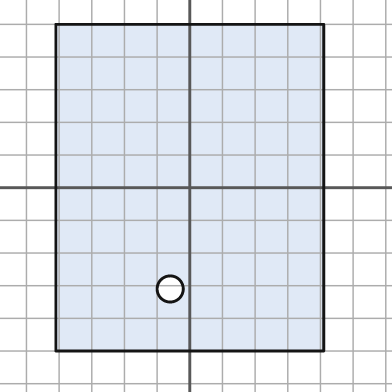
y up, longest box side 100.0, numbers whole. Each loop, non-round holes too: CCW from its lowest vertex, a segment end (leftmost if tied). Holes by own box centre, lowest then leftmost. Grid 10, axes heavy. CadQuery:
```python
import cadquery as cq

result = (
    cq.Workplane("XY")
    .moveTo(-41.0, -50.0)
    .lineTo(41.0, -50.0)
    .lineTo(41.0, 50.0)
    .lineTo(-41.0, 50.0)
    .close()
    .moveTo(-6.0, -31.0)
    .circle(4.0)
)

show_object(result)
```